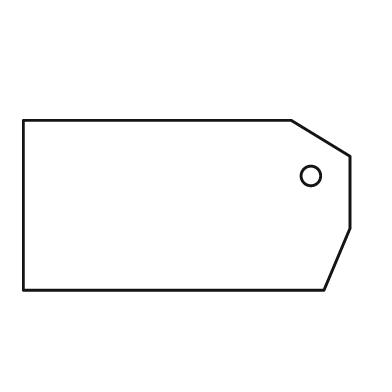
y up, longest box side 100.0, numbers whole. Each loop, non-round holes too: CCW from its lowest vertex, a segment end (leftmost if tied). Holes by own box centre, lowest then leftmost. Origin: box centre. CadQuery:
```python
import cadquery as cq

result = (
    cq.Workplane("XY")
    .moveTo(-50.0, -26.0)
    .lineTo(42.0, -26.0)
    .lineTo(50.0, -7.0)
    .lineTo(50.0, 15.0)
    .lineTo(32.0, 26.0)
    .lineTo(-50.0, 26.0)
    .close()
    .moveTo(38.0, 9.0)
    .circle(3.0)
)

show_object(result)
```